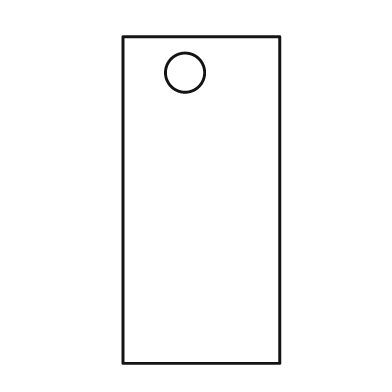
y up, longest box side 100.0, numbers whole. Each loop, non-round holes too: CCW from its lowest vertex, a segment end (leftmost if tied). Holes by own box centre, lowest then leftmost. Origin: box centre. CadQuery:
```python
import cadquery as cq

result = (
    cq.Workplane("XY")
    .moveTo(-24.0, -50.0)
    .lineTo(24.0, -50.0)
    .lineTo(24.0, 50.0)
    .lineTo(-24.0, 50.0)
    .close()
    .moveTo(-5.0, 39.0)
    .circle(6.0)
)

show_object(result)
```